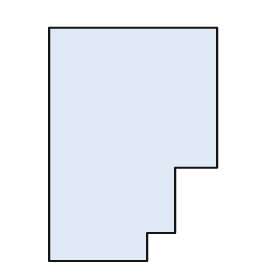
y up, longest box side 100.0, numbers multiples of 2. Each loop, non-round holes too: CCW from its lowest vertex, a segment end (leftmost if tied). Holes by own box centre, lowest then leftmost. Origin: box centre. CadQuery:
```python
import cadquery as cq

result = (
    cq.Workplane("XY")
    .moveTo(-36.0, -50.0)
    .lineTo(6.0, -50.0)
    .lineTo(6.0, -38.0)
    .lineTo(18.0, -38.0)
    .lineTo(18.0, -10.0)
    .lineTo(36.0, -10.0)
    .lineTo(36.0, 50.0)
    .lineTo(-36.0, 50.0)
    .close()
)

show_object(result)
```